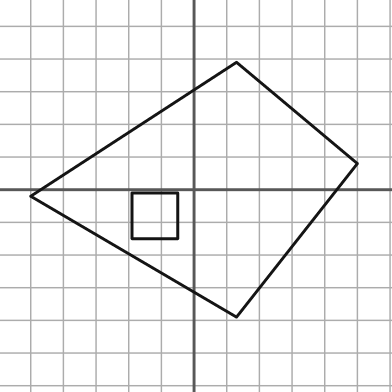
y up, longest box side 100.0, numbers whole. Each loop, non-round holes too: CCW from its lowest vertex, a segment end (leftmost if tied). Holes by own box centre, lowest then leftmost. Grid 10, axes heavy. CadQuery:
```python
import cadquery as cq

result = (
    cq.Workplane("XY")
    .moveTo(13.0, -39.0)
    .lineTo(50.0, 8.0)
    .lineTo(13.0, 39.0)
    .lineTo(-50.0, -2.0)
    .close()
    .moveTo(-19.0, -15.0)
    .lineTo(-5.0, -15.0)
    .lineTo(-5.0, -1.0)
    .lineTo(-19.0, -1.0)
    .close()
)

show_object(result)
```